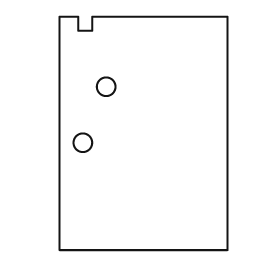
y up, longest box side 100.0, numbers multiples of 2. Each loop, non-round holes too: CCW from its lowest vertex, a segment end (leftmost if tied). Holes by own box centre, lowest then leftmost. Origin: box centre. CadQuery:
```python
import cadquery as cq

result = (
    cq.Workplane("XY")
    .moveTo(-36.0, -50.0)
    .lineTo(36.0, -50.0)
    .lineTo(36.0, 50.0)
    .lineTo(-22.0, 50.0)
    .lineTo(-22.0, 44.0)
    .lineTo(-28.0, 44.0)
    .lineTo(-28.0, 50.0)
    .lineTo(-36.0, 50.0)
    .close()
    .moveTo(-26.0, -4.0)
    .circle(4.0)
    .moveTo(-16.0, 20.0)
    .circle(4.0)
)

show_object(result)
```